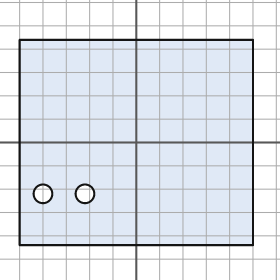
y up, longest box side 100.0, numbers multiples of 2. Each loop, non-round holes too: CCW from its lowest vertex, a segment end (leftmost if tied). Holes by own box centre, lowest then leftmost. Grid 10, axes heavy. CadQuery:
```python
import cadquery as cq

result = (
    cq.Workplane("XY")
    .moveTo(-50.0, -44.0)
    .lineTo(50.0, -44.0)
    .lineTo(50.0, 44.0)
    .lineTo(-50.0, 44.0)
    .close()
    .moveTo(-40.0, -22.0)
    .circle(4.0)
    .moveTo(-22.0, -22.0)
    .circle(4.0)
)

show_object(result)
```